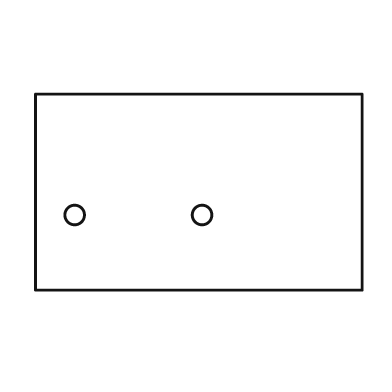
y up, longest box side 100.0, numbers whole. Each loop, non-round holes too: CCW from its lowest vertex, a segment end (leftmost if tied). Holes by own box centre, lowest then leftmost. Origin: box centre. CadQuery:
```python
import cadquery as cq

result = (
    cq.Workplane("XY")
    .moveTo(-50.0, -30.0)
    .lineTo(50.0, -30.0)
    .lineTo(50.0, 30.0)
    .lineTo(-50.0, 30.0)
    .close()
    .moveTo(-38.0, -7.0)
    .circle(3.0)
    .moveTo(1.0, -7.0)
    .circle(3.0)
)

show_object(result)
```